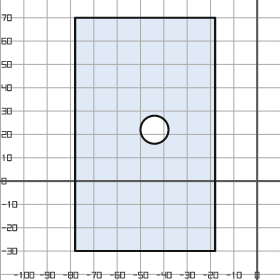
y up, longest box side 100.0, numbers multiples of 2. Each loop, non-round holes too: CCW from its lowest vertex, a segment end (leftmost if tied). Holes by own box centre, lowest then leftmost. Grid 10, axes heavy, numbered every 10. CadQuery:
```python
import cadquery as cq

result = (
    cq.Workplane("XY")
    .moveTo(-78.0, -30.0)
    .lineTo(-18.0, -30.0)
    .lineTo(-18.0, 70.0)
    .lineTo(-78.0, 70.0)
    .close()
    .moveTo(-44.0, 22.0)
    .circle(6.0)
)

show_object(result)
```